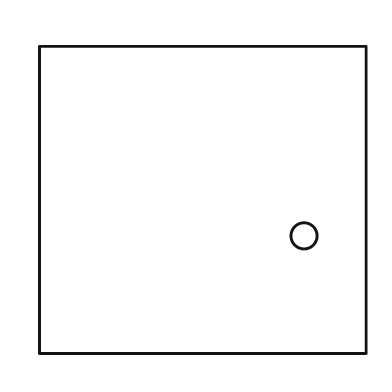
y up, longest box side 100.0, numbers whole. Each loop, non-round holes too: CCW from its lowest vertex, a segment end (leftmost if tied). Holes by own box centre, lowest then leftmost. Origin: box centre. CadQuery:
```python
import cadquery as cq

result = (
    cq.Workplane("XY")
    .moveTo(-50.0, -47.0)
    .lineTo(50.0, -47.0)
    .lineTo(50.0, 47.0)
    .lineTo(-50.0, 47.0)
    .close()
    .moveTo(31.0, -11.0)
    .circle(4.0)
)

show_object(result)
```